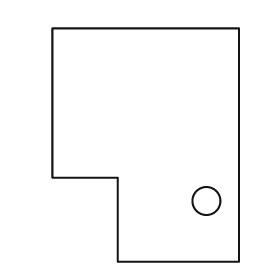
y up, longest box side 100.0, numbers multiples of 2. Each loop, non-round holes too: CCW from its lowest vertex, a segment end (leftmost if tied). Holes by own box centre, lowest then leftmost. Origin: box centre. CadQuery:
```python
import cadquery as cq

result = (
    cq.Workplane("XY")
    .moveTo(-12.0, -50.0)
    .lineTo(40.0, -50.0)
    .lineTo(40.0, 50.0)
    .lineTo(-40.0, 50.0)
    .lineTo(-40.0, -14.0)
    .lineTo(-12.0, -14.0)
    .close()
    .moveTo(26.0, -24.0)
    .circle(6.0)
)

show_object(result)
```